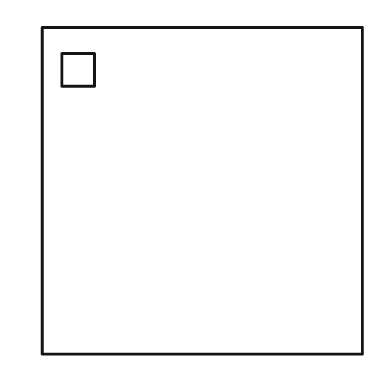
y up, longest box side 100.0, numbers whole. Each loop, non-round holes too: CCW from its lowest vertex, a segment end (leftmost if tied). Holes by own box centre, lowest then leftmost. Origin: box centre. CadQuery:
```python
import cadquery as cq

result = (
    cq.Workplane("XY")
    .moveTo(-49.0, -50.0)
    .lineTo(49.0, -50.0)
    .lineTo(49.0, 50.0)
    .lineTo(-49.0, 50.0)
    .close()
    .moveTo(-43.0, 32.0)
    .lineTo(-33.0, 32.0)
    .lineTo(-33.0, 42.0)
    .lineTo(-43.0, 42.0)
    .close()
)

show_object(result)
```